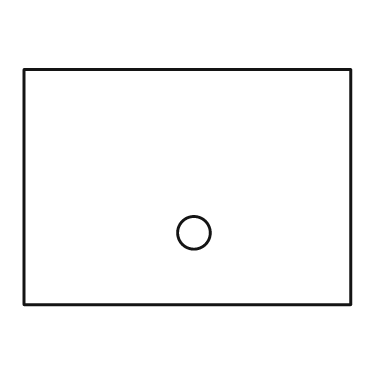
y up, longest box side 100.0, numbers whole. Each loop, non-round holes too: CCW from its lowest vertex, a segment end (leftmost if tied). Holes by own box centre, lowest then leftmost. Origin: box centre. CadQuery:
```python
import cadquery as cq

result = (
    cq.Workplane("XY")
    .moveTo(-50.0, -36.0)
    .lineTo(50.0, -36.0)
    .lineTo(50.0, 36.0)
    .lineTo(-50.0, 36.0)
    .close()
    .moveTo(2.0, -14.0)
    .circle(5.0)
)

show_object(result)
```